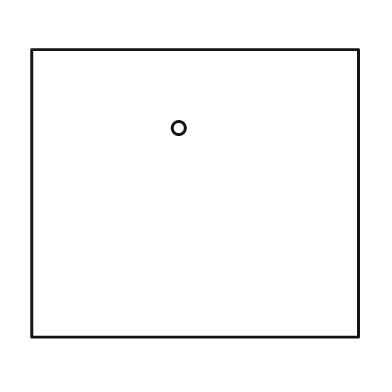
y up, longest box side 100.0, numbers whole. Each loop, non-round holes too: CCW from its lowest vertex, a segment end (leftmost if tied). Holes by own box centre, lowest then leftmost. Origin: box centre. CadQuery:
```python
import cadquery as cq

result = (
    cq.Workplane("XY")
    .moveTo(-50.0, -44.0)
    .lineTo(50.0, -44.0)
    .lineTo(50.0, 44.0)
    .lineTo(-50.0, 44.0)
    .close()
    .moveTo(-5.0, 20.0)
    .circle(2.0)
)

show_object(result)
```